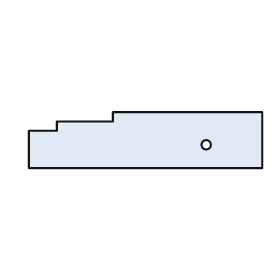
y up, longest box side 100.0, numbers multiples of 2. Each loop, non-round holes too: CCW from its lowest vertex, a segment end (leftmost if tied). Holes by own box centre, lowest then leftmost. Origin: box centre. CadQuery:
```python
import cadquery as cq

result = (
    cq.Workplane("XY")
    .moveTo(-50.0, -12.0)
    .lineTo(50.0, -12.0)
    .lineTo(50.0, 12.0)
    .lineTo(-14.0, 12.0)
    .lineTo(-14.0, 8.0)
    .lineTo(-38.0, 8.0)
    .lineTo(-38.0, 4.0)
    .lineTo(-50.0, 4.0)
    .close()
    .moveTo(26.0, -2.0)
    .circle(2.0)
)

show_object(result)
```